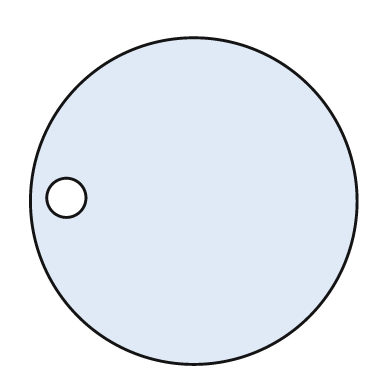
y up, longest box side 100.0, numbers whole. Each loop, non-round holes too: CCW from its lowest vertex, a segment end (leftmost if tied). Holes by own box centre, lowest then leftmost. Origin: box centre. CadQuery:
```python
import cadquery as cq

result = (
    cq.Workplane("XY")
    .moveTo(0.0, 0.0)
    .circle(50.0)
    .moveTo(-39.0, 1.0)
    .circle(6.0)
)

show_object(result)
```